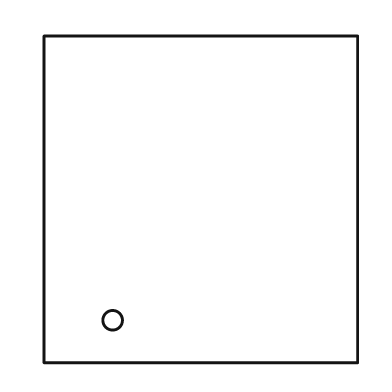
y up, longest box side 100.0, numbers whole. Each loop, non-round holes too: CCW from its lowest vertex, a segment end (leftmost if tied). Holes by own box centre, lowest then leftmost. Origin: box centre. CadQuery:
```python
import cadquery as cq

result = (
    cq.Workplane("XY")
    .moveTo(-48.0, -50.0)
    .lineTo(48.0, -50.0)
    .lineTo(48.0, 50.0)
    .lineTo(-48.0, 50.0)
    .close()
    .moveTo(-27.0, -37.0)
    .circle(3.0)
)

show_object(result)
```